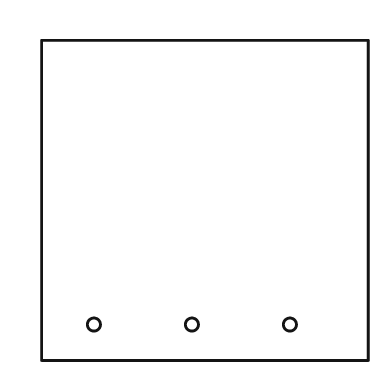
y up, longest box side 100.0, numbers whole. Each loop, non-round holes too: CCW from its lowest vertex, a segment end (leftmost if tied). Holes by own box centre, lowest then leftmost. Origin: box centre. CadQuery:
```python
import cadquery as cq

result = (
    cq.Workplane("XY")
    .moveTo(-50.0, -49.0)
    .lineTo(50.0, -49.0)
    .lineTo(50.0, 49.0)
    .lineTo(-50.0, 49.0)
    .close()
    .moveTo(-34.0, -38.0)
    .circle(2.0)
    .moveTo(-4.0, -38.0)
    .circle(2.0)
    .moveTo(26.0, -38.0)
    .circle(2.0)
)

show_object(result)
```